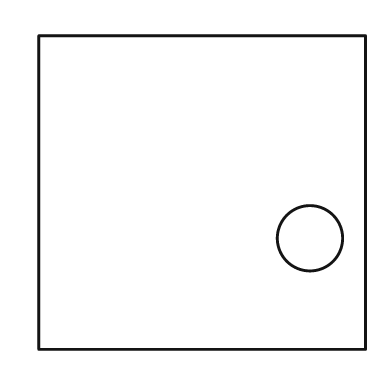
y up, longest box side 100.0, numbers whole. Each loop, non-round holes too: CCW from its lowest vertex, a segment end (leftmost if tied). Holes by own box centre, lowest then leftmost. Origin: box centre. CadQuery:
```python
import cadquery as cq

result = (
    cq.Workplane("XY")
    .moveTo(-50.0, -48.0)
    .lineTo(50.0, -48.0)
    .lineTo(50.0, 48.0)
    .lineTo(-50.0, 48.0)
    .close()
    .moveTo(33.0, -14.0)
    .circle(10.0)
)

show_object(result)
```